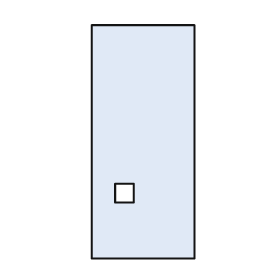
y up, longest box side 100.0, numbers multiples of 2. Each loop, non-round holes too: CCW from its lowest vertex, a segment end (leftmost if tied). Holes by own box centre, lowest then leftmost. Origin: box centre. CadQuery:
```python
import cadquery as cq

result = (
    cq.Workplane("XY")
    .moveTo(-22.0, -50.0)
    .lineTo(22.0, -50.0)
    .lineTo(22.0, 50.0)
    .lineTo(-22.0, 50.0)
    .close()
    .moveTo(-12.0, -26.0)
    .lineTo(-4.0, -26.0)
    .lineTo(-4.0, -18.0)
    .lineTo(-12.0, -18.0)
    .close()
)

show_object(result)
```